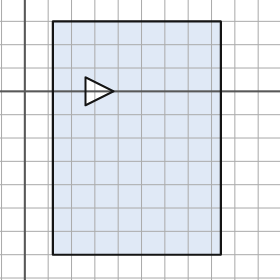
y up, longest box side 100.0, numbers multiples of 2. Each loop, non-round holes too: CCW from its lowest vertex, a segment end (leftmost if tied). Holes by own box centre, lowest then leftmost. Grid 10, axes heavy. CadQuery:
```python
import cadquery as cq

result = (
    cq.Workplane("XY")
    .moveTo(12.0, -70.0)
    .lineTo(84.0, -70.0)
    .lineTo(84.0, 30.0)
    .lineTo(12.0, 30.0)
    .close()
    .moveTo(26.0, -6.0)
    .lineTo(38.0, 0.0)
    .lineTo(26.0, 6.0)
    .close()
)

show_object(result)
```